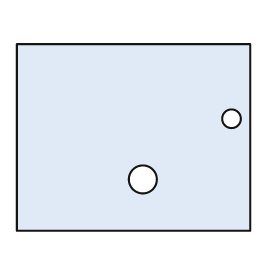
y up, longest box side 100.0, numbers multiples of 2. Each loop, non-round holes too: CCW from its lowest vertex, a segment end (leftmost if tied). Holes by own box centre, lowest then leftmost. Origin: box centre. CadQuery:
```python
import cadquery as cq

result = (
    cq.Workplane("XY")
    .moveTo(-50.0, -40.0)
    .lineTo(50.0, -40.0)
    .lineTo(50.0, 40.0)
    .lineTo(-50.0, 40.0)
    .close()
    .moveTo(4.0, -18.0)
    .circle(6.0)
    .moveTo(42.0, 8.0)
    .circle(4.0)
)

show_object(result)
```